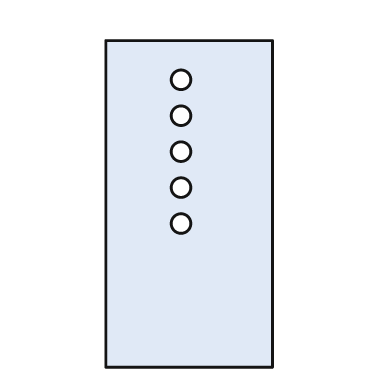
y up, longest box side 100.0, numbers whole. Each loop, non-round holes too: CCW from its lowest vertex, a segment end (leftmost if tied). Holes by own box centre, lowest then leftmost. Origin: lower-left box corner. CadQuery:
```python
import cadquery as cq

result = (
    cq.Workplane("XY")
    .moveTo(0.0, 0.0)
    .lineTo(51.0, 0.0)
    .lineTo(51.0, 100.0)
    .lineTo(0.0, 100.0)
    .close()
    .moveTo(23.0, 44.0)
    .circle(3.0)
    .moveTo(23.0, 55.0)
    .circle(3.0)
    .moveTo(23.0, 66.0)
    .circle(3.0)
    .moveTo(23.0, 77.0)
    .circle(3.0)
    .moveTo(23.0, 88.0)
    .circle(3.0)
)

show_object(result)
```